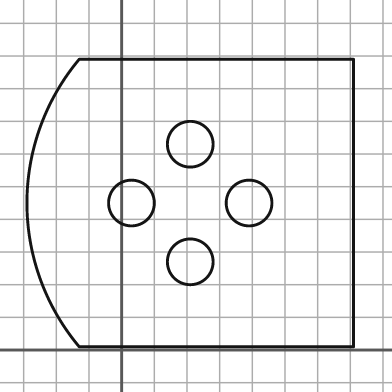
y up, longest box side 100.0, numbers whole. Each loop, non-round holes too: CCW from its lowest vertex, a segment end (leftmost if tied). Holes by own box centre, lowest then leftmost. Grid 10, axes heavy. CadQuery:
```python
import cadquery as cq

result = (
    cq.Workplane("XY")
    .moveTo(-13.0, 1.0)
    .lineTo(71.0, 1.0)
    .lineTo(71.0, 89.0)
    .lineTo(-13.0, 89.0)
    .threePointArc((-29.0, 45.0), (-13.0, 1.0))
    .close()
    .moveTo(21.0, 27.0)
    .circle(7.0)
    .moveTo(3.0, 45.0)
    .circle(7.0)
    .moveTo(39.0, 45.0)
    .circle(7.0)
    .moveTo(21.0, 63.0)
    .circle(7.0)
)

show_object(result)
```